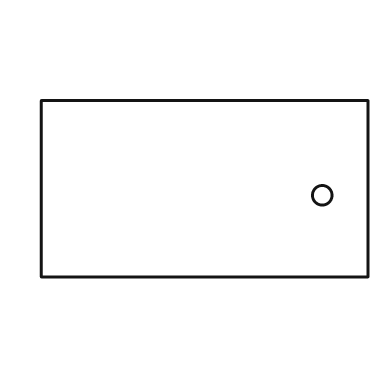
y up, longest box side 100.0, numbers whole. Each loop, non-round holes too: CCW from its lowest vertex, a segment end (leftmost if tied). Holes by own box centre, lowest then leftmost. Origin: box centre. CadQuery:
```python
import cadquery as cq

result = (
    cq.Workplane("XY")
    .moveTo(-50.0, -27.0)
    .lineTo(50.0, -27.0)
    .lineTo(50.0, 27.0)
    .lineTo(-50.0, 27.0)
    .close()
    .moveTo(36.0, -2.0)
    .circle(3.0)
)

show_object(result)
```